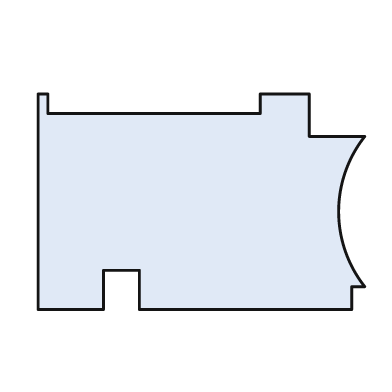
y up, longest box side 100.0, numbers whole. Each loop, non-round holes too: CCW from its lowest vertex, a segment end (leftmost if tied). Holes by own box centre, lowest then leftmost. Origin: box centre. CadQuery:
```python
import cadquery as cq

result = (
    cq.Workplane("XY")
    .moveTo(-50.0, -33.0)
    .lineTo(-30.0, -33.0)
    .lineTo(-30.0, -21.0)
    .lineTo(-19.0, -21.0)
    .lineTo(-19.0, -33.0)
    .lineTo(46.0, -33.0)
    .lineTo(46.0, -26.0)
    .lineTo(50.0, -26.0)
    .threePointArc((42.0, -3.0), (50.0, 20.0))
    .lineTo(33.0, 20.0)
    .lineTo(33.0, 33.0)
    .lineTo(18.0, 33.0)
    .lineTo(18.0, 27.0)
    .lineTo(-47.0, 27.0)
    .lineTo(-47.0, 33.0)
    .lineTo(-50.0, 33.0)
    .close()
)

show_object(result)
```